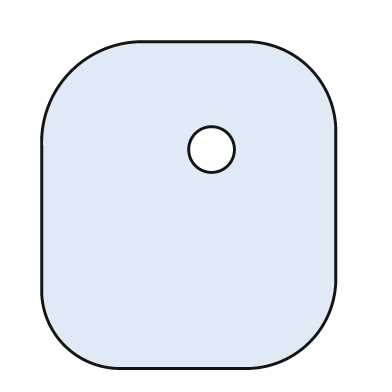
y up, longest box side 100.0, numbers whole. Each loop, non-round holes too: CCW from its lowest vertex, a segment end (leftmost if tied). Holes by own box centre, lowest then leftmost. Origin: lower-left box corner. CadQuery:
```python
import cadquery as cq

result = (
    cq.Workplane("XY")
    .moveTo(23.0, 0.0)
    .lineTo(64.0, 0.0)
    .threePointArc((82.0, 8.0), (90.0, 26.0))
    .lineTo(90.0, 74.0)
    .threePointArc((82.0, 92.0), (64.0, 100.0))
    .lineTo(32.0, 100.0)
    .threePointArc((9.0, 91.0), (0.0, 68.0))
    .lineTo(0.0, 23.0)
    .threePointArc((7.0, 7.0), (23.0, 0.0))
    .close()
    .moveTo(52.0, 67.0)
    .circle(7.0)
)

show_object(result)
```